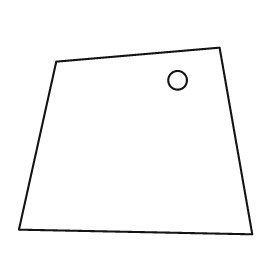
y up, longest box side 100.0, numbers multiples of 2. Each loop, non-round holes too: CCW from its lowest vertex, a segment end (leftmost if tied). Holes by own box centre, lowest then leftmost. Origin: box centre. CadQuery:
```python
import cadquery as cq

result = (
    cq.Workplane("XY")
    .moveTo(50.0, -40.0)
    .lineTo(36.0, 40.0)
    .lineTo(-34.0, 34.0)
    .lineTo(-50.0, -38.0)
    .close()
    .moveTo(18.0, 26.0)
    .circle(4.0)
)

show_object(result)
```